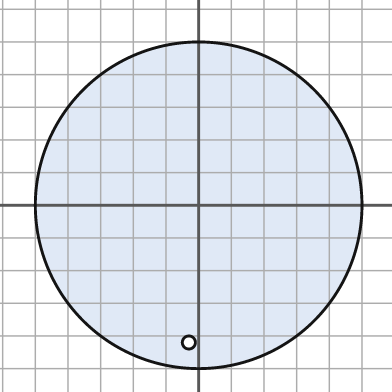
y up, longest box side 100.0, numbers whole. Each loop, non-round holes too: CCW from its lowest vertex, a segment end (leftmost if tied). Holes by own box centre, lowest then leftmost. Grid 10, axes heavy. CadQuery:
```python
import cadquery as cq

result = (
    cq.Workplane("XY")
    .moveTo(0.0, 0.0)
    .circle(50.0)
    .moveTo(-3.0, -42.0)
    .circle(2.0)
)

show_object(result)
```